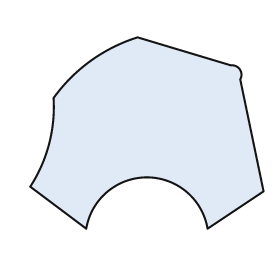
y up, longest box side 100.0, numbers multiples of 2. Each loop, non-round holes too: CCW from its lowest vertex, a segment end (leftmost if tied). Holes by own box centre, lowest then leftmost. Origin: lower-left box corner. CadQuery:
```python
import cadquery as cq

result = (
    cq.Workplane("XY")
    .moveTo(24.0, 0.0)
    .threePointArc((50.0, 22.0), (76.0, 0.0))
    .lineTo(100.0, 16.0)
    .lineTo(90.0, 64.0)
    .threePointArc((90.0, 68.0), (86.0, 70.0))
    .lineTo(46.0, 82.0)
    .threePointArc((26.0, 72.0), (10.0, 56.0))
    .threePointArc((8.0, 36.0), (0.0, 18.0))
    .close()
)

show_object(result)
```